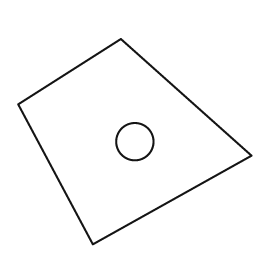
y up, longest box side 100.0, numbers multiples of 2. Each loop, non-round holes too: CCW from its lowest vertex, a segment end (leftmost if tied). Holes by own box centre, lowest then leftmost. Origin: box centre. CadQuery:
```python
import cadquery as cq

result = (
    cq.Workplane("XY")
    .moveTo(-18.0, -44.0)
    .lineTo(50.0, -6.0)
    .lineTo(-6.0, 44.0)
    .lineTo(-50.0, 16.0)
    .close()
    .moveTo(0.0, 0.0)
    .circle(8.0)
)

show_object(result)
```